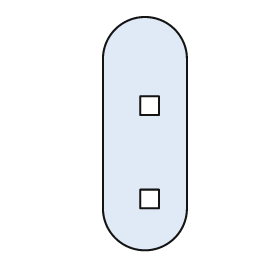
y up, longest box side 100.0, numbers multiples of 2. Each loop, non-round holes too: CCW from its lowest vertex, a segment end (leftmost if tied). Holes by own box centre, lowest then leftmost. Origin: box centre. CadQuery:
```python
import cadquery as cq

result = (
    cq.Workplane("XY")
    .moveTo(-18.0, -32.0)
    .threePointArc((0.0, -50.0), (18.0, -32.0))
    .lineTo(18.0, 32.0)
    .threePointArc((0.0, 50.0), (-18.0, 32.0))
    .close()
    .moveTo(-2.0, -32.0)
    .lineTo(6.0, -32.0)
    .lineTo(6.0, -24.0)
    .lineTo(-2.0, -24.0)
    .close()
    .moveTo(-2.0, 8.0)
    .lineTo(6.0, 8.0)
    .lineTo(6.0, 16.0)
    .lineTo(-2.0, 16.0)
    .close()
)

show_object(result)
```